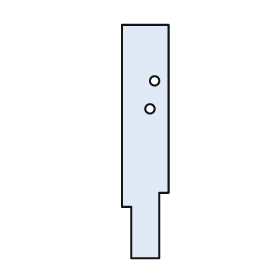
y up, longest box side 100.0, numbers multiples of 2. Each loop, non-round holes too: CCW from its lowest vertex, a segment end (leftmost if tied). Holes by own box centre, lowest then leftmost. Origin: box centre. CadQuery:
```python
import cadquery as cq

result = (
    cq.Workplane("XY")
    .moveTo(-6.0, -50.0)
    .lineTo(6.0, -50.0)
    .lineTo(6.0, -22.0)
    .lineTo(10.0, -22.0)
    .lineTo(10.0, 50.0)
    .lineTo(-10.0, 50.0)
    .lineTo(-10.0, -28.0)
    .lineTo(-6.0, -28.0)
    .close()
    .moveTo(2.0, 14.0)
    .circle(2.0)
    .moveTo(4.0, 26.0)
    .circle(2.0)
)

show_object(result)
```